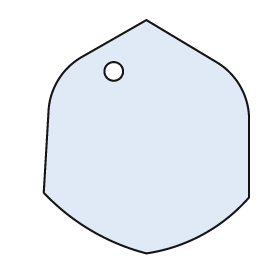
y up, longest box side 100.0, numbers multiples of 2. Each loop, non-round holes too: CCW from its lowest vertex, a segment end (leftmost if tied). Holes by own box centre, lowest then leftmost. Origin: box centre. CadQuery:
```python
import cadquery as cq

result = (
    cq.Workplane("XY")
    .moveTo(0.0, -50.0)
    .threePointArc((24.0, -42.0), (44.0, -26.0))
    .lineTo(44.0, 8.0)
    .threePointArc((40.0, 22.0), (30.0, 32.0))
    .lineTo(0.0, 50.0)
    .lineTo(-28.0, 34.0)
    .threePointArc((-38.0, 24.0), (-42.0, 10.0))
    .lineTo(-44.0, -24.0)
    .threePointArc((-24.0, -40.0), (0.0, -50.0))
    .close()
    .moveTo(-14.0, 28.0)
    .circle(4.0)
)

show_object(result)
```